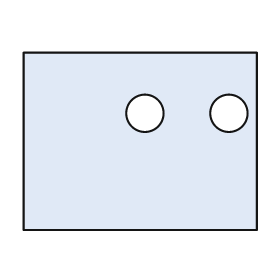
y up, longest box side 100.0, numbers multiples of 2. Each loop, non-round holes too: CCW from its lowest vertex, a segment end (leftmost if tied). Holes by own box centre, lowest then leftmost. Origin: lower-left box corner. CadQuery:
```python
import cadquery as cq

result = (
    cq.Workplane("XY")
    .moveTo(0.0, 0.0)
    .lineTo(100.0, 0.0)
    .lineTo(100.0, 76.0)
    .lineTo(0.0, 76.0)
    .close()
    .moveTo(52.0, 50.0)
    .circle(8.0)
    .moveTo(88.0, 50.0)
    .circle(8.0)
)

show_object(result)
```